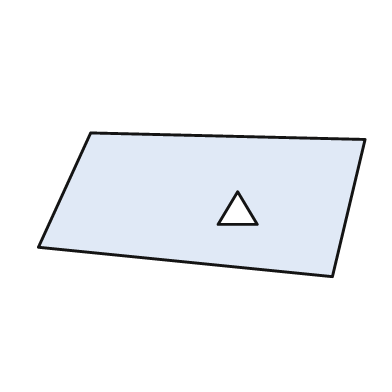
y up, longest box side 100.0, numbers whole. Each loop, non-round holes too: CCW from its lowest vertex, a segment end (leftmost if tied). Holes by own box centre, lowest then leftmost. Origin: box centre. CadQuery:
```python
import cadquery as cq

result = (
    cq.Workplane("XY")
    .moveTo(40.0, -22.0)
    .lineTo(50.0, 20.0)
    .lineTo(-34.0, 22.0)
    .lineTo(-50.0, -13.0)
    .close()
    .moveTo(5.0, -6.0)
    .lineTo(17.0, -6.0)
    .lineTo(11.0, 4.0)
    .close()
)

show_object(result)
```